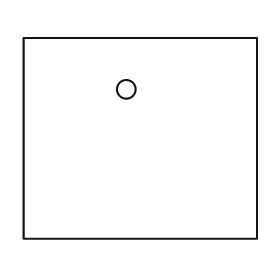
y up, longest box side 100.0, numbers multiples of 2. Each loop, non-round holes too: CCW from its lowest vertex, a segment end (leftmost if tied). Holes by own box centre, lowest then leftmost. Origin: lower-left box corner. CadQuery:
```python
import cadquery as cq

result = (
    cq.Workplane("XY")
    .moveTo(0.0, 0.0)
    .lineTo(100.0, 0.0)
    .lineTo(100.0, 86.0)
    .lineTo(0.0, 86.0)
    .close()
    .moveTo(44.0, 64.0)
    .circle(4.0)
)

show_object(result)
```